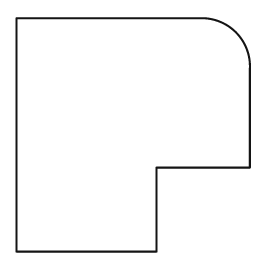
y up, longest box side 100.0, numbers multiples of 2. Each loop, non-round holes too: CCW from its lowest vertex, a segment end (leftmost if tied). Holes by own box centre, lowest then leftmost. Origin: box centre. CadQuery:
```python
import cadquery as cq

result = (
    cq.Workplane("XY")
    .moveTo(-50.0, -50.0)
    .lineTo(10.0, -50.0)
    .lineTo(10.0, -14.0)
    .lineTo(50.0, -14.0)
    .lineTo(50.0, 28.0)
    .threePointArc((44.0, 44.0), (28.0, 50.0))
    .lineTo(-50.0, 50.0)
    .close()
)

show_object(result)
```